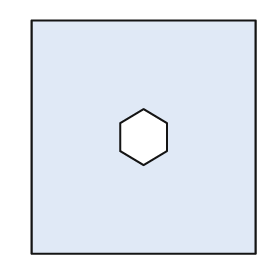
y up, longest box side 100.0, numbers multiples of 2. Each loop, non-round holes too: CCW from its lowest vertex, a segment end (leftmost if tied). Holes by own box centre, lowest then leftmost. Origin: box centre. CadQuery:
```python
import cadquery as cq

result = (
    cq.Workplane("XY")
    .moveTo(-48.0, -50.0)
    .lineTo(48.0, -50.0)
    .lineTo(48.0, 50.0)
    .lineTo(-48.0, 50.0)
    .close()
    .moveTo(0.0, -12.0)
    .lineTo(10.0, -6.0)
    .lineTo(10.0, 6.0)
    .lineTo(0.0, 12.0)
    .lineTo(-10.0, 6.0)
    .lineTo(-10.0, -6.0)
    .close()
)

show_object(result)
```